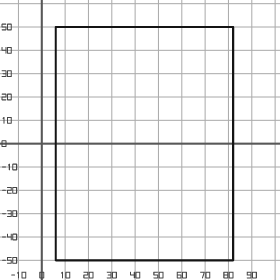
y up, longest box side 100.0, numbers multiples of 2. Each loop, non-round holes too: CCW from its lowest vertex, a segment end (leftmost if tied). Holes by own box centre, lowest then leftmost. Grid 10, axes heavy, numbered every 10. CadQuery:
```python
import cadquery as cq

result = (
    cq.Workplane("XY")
    .moveTo(6.0, -50.0)
    .lineTo(82.0, -50.0)
    .lineTo(82.0, 50.0)
    .lineTo(6.0, 50.0)
    .close()
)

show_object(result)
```